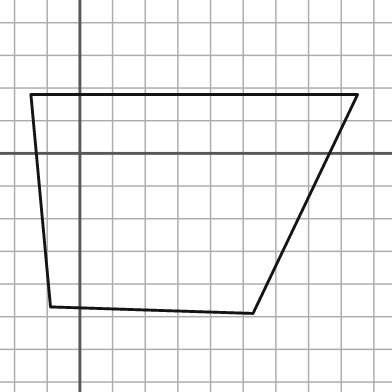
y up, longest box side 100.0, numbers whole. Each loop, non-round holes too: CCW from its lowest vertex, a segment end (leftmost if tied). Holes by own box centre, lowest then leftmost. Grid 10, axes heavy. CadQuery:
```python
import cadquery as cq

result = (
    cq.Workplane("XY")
    .moveTo(53.0, -49.0)
    .lineTo(85.0, 18.0)
    .lineTo(-15.0, 18.0)
    .lineTo(-9.0, -47.0)
    .close()
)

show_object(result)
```